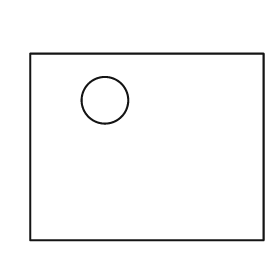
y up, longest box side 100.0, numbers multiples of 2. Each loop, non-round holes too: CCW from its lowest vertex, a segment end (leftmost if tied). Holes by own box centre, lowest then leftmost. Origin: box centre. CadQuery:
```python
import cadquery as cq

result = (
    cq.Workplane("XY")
    .moveTo(-50.0, -40.0)
    .lineTo(50.0, -40.0)
    .lineTo(50.0, 40.0)
    .lineTo(-50.0, 40.0)
    .close()
    .moveTo(-18.0, 20.0)
    .circle(10.0)
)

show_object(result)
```